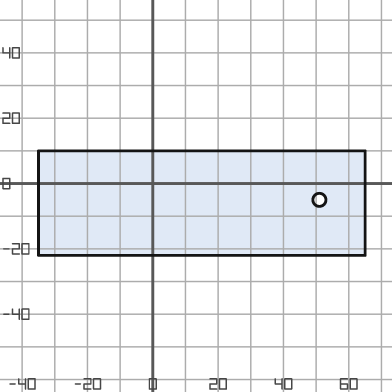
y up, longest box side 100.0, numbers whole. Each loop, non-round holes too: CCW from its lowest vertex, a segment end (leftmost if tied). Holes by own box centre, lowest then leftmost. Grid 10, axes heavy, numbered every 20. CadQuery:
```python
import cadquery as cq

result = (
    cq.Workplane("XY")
    .moveTo(-35.0, -22.0)
    .lineTo(65.0, -22.0)
    .lineTo(65.0, 10.0)
    .lineTo(-35.0, 10.0)
    .close()
    .moveTo(51.0, -5.0)
    .circle(2.0)
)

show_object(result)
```